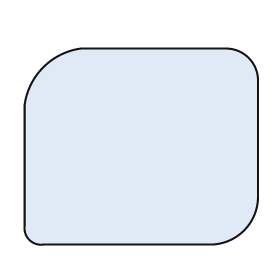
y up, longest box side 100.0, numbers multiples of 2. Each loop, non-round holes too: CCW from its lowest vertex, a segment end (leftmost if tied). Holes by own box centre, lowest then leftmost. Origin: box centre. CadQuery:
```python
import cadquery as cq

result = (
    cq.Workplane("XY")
    .moveTo(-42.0, -42.0)
    .lineTo(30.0, -42.0)
    .threePointArc((44.0, -36.0), (50.0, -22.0))
    .lineTo(50.0, 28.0)
    .threePointArc((46.0, 38.0), (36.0, 42.0))
    .lineTo(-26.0, 42.0)
    .threePointArc((-42.0, 34.0), (-50.0, 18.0))
    .lineTo(-50.0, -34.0)
    .threePointArc((-48.0, -40.0), (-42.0, -42.0))
    .close()
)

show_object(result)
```